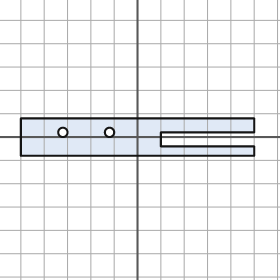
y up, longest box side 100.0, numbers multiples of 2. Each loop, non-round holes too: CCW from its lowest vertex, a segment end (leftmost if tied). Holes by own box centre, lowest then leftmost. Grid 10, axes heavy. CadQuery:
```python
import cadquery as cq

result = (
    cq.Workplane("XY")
    .moveTo(-50.0, -8.0)
    .lineTo(50.0, -8.0)
    .lineTo(50.0, -4.0)
    .lineTo(10.0, -4.0)
    .lineTo(10.0, 2.0)
    .lineTo(50.0, 2.0)
    .lineTo(50.0, 8.0)
    .lineTo(-50.0, 8.0)
    .close()
    .moveTo(-32.0, 2.0)
    .circle(2.0)
    .moveTo(-12.0, 2.0)
    .circle(2.0)
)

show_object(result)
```